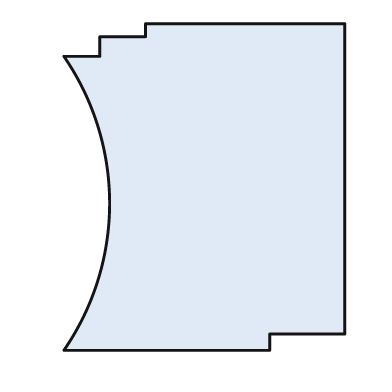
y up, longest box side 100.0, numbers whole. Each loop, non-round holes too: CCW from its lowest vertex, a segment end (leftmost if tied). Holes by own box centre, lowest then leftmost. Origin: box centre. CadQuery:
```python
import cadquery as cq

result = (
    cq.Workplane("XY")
    .moveTo(-43.0, -50.0)
    .lineTo(20.0, -50.0)
    .lineTo(20.0, -45.0)
    .lineTo(43.0, -45.0)
    .lineTo(43.0, 50.0)
    .lineTo(-18.0, 50.0)
    .lineTo(-18.0, 46.0)
    .lineTo(-32.0, 46.0)
    .lineTo(-32.0, 40.0)
    .lineTo(-43.0, 40.0)
    .threePointArc((-29.0, -5.0), (-43.0, -50.0))
    .close()
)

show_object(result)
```